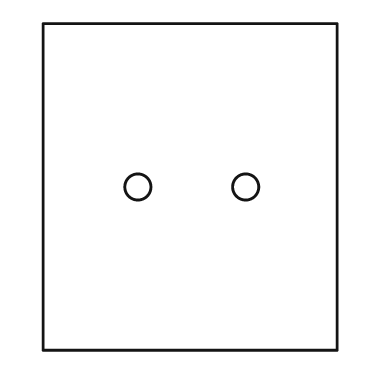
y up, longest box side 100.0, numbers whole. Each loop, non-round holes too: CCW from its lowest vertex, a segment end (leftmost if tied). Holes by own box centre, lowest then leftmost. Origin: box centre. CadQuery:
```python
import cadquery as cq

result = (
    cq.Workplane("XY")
    .moveTo(-45.0, -50.0)
    .lineTo(45.0, -50.0)
    .lineTo(45.0, 50.0)
    .lineTo(-45.0, 50.0)
    .close()
    .moveTo(-16.0, 0.0)
    .circle(4.0)
    .moveTo(17.0, 0.0)
    .circle(4.0)
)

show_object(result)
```